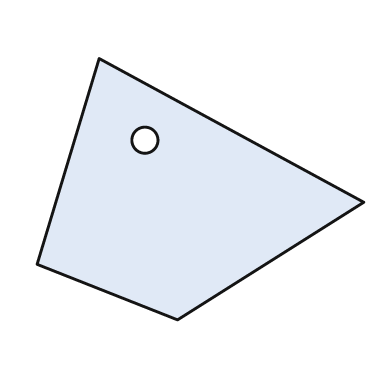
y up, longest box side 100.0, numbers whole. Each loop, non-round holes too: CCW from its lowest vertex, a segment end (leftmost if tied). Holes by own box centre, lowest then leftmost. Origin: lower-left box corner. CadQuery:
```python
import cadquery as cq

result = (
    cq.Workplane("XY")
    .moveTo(43.0, 0.0)
    .lineTo(100.0, 36.0)
    .lineTo(19.0, 80.0)
    .lineTo(0.0, 17.0)
    .close()
    .moveTo(33.0, 55.0)
    .circle(4.0)
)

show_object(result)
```